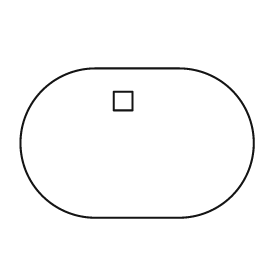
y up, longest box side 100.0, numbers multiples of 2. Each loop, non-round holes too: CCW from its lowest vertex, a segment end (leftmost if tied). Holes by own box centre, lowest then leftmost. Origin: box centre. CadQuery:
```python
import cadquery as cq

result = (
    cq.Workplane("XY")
    .moveTo(-18.0, -32.0)
    .lineTo(18.0, -32.0)
    .threePointArc((50.0, 0.0), (18.0, 32.0))
    .lineTo(-18.0, 32.0)
    .threePointArc((-50.0, 0.0), (-18.0, -32.0))
    .close()
    .moveTo(-10.0, 14.0)
    .lineTo(-2.0, 14.0)
    .lineTo(-2.0, 22.0)
    .lineTo(-10.0, 22.0)
    .close()
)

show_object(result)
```